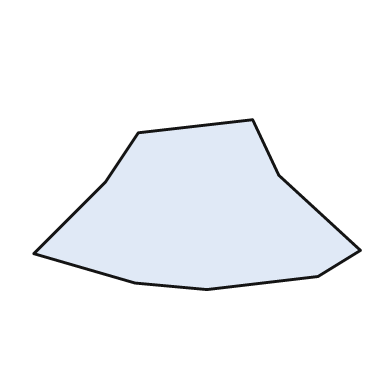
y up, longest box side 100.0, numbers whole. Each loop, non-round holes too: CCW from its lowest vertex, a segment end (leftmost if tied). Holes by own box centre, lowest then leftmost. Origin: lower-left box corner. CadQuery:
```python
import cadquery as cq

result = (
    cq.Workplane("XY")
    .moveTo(53.0, 0.0)
    .lineTo(87.0, 4.0)
    .lineTo(100.0, 12.0)
    .lineTo(75.0, 35.0)
    .lineTo(67.0, 52.0)
    .lineTo(32.0, 48.0)
    .lineTo(22.0, 33.0)
    .lineTo(0.0, 11.0)
    .lineTo(31.0, 2.0)
    .close()
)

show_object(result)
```